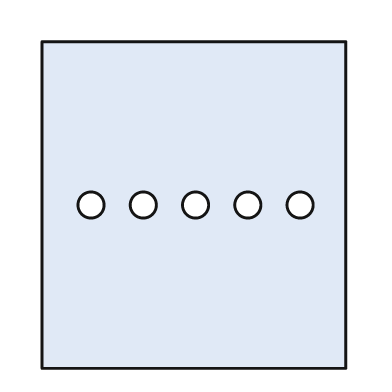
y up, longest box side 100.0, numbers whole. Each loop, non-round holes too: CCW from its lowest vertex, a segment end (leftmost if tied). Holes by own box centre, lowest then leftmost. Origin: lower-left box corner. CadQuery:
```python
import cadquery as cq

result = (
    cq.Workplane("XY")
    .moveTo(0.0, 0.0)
    .lineTo(93.0, 0.0)
    .lineTo(93.0, 100.0)
    .lineTo(0.0, 100.0)
    .close()
    .moveTo(15.0, 50.0)
    .circle(4.0)
    .moveTo(31.0, 50.0)
    .circle(4.0)
    .moveTo(47.0, 50.0)
    .circle(4.0)
    .moveTo(63.0, 50.0)
    .circle(4.0)
    .moveTo(79.0, 50.0)
    .circle(4.0)
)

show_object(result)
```